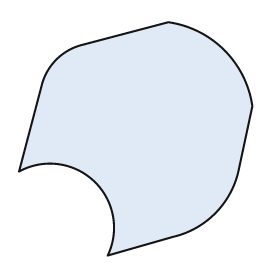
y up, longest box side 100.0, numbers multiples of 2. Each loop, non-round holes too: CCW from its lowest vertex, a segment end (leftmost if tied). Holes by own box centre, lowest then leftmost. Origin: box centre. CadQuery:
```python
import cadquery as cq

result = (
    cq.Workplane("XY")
    .moveTo(-12.0, -50.0)
    .lineTo(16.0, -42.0)
    .threePointArc((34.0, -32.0), (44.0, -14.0))
    .lineTo(50.0, 14.0)
    .threePointArc((38.0, 38.0), (14.0, 50.0))
    .lineTo(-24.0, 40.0)
    .threePointArc((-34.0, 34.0), (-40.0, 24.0))
    .lineTo(-50.0, -14.0)
    .threePointArc((-18.0, -18.0), (-12.0, -50.0))
    .close()
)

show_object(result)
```